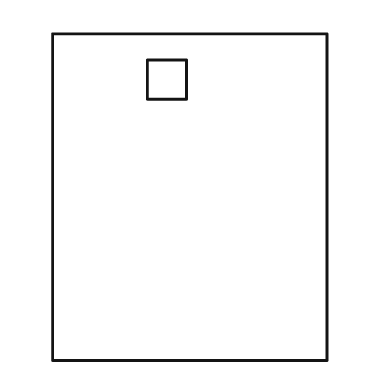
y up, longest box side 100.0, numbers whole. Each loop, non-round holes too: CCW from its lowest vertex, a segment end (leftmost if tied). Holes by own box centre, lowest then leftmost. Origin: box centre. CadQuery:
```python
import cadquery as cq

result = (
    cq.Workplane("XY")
    .moveTo(-42.0, -50.0)
    .lineTo(42.0, -50.0)
    .lineTo(42.0, 50.0)
    .lineTo(-42.0, 50.0)
    .close()
    .moveTo(-13.0, 30.0)
    .lineTo(-1.0, 30.0)
    .lineTo(-1.0, 42.0)
    .lineTo(-13.0, 42.0)
    .close()
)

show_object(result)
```